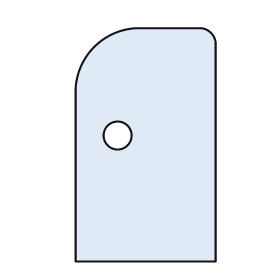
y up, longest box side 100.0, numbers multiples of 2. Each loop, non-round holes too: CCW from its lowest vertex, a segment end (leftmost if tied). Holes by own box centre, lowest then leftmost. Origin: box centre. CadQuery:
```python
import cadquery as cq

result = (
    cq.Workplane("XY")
    .moveTo(-30.0, -50.0)
    .lineTo(30.0, -50.0)
    .lineTo(30.0, 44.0)
    .threePointArc((28.0, 48.0), (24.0, 50.0))
    .lineTo(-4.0, 50.0)
    .threePointArc((-22.0, 42.0), (-30.0, 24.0))
    .close()
    .moveTo(-12.0, 4.0)
    .circle(6.0)
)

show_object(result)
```